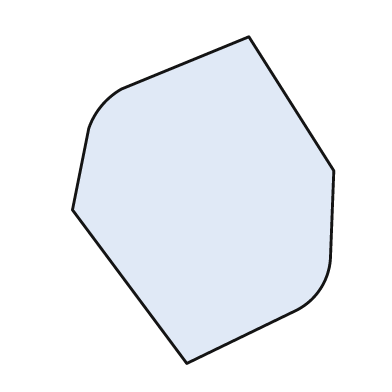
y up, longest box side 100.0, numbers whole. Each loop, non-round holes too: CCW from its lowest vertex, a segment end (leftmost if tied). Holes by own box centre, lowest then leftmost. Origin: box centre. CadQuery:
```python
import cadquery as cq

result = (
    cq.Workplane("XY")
    .moveTo(-5.0, -50.0)
    .lineTo(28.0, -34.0)
    .threePointArc((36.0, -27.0), (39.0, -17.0))
    .lineTo(40.0, 9.0)
    .lineTo(14.0, 50.0)
    .lineTo(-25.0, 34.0)
    .threePointArc((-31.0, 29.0), (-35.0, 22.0))
    .lineTo(-40.0, -3.0)
    .close()
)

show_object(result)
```